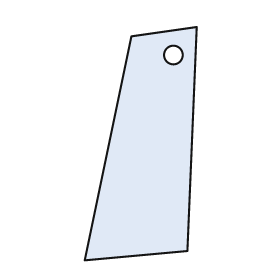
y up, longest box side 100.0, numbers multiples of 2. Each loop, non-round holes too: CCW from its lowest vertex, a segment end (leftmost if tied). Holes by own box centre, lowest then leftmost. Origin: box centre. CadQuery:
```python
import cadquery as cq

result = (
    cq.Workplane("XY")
    .moveTo(-24.0, -50.0)
    .lineTo(20.0, -46.0)
    .lineTo(24.0, 50.0)
    .lineTo(-4.0, 46.0)
    .close()
    .moveTo(14.0, 38.0)
    .circle(4.0)
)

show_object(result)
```